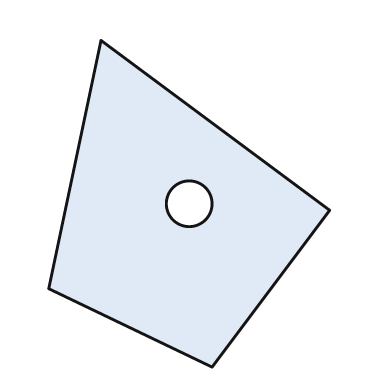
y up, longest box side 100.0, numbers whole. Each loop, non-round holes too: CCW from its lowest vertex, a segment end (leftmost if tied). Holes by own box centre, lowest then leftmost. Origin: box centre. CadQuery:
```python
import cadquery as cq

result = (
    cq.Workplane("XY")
    .moveTo(7.0, -50.0)
    .lineTo(43.0, -2.0)
    .lineTo(-27.0, 50.0)
    .lineTo(-43.0, -26.0)
    .close()
    .moveTo(0.0, 0.0)
    .circle(7.0)
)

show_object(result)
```